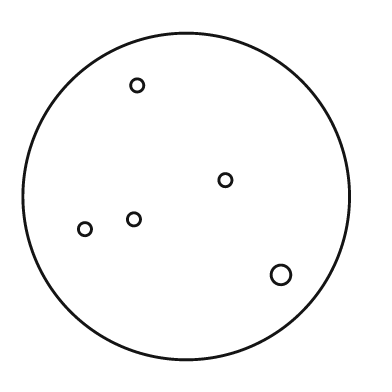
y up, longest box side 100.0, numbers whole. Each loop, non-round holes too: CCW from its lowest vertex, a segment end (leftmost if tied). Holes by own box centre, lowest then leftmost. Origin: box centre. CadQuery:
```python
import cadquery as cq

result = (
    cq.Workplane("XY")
    .moveTo(0.0, 0.0)
    .circle(50.0)
    .moveTo(29.0, -24.0)
    .circle(3.0)
    .moveTo(-31.0, -10.0)
    .circle(2.0)
    .moveTo(-16.0, -7.0)
    .circle(2.0)
    .moveTo(12.0, 5.0)
    .circle(2.0)
    .moveTo(-15.0, 34.0)
    .circle(2.0)
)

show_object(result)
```